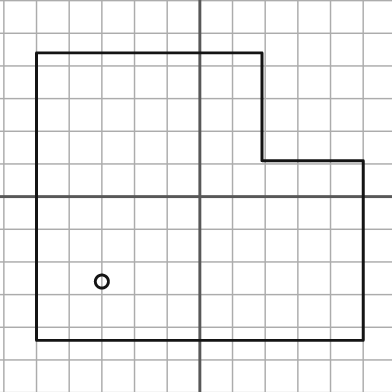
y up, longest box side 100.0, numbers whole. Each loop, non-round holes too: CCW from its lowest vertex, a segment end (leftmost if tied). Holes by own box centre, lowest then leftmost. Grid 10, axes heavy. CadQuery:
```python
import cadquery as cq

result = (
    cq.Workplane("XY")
    .moveTo(-50.0, -44.0)
    .lineTo(50.0, -44.0)
    .lineTo(50.0, 11.0)
    .lineTo(19.0, 11.0)
    .lineTo(19.0, 44.0)
    .lineTo(-50.0, 44.0)
    .close()
    .moveTo(-30.0, -26.0)
    .circle(2.0)
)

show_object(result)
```